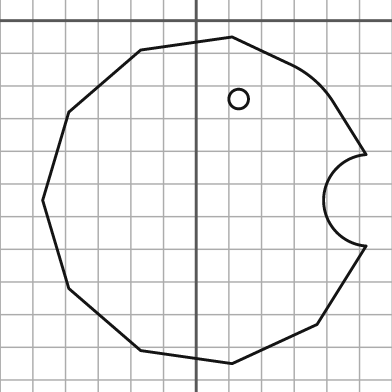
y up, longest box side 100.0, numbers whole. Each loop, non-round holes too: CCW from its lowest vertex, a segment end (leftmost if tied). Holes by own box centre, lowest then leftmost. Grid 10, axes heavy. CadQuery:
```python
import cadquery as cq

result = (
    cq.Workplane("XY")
    .moveTo(11.0, -105.0)
    .lineTo(37.0, -93.0)
    .lineTo(52.0, -69.0)
    .threePointArc((39.0, -55.0), (52.0, -41.0))
    .lineTo(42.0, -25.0)
    .threePointArc((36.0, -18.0), (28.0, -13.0))
    .lineTo(11.0, -5.0)
    .lineTo(-17.0, -9.0)
    .lineTo(-39.0, -28.0)
    .lineTo(-47.0, -55.0)
    .lineTo(-39.0, -82.0)
    .lineTo(-17.0, -101.0)
    .close()
    .moveTo(13.0, -24.0)
    .circle(3.0)
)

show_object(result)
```